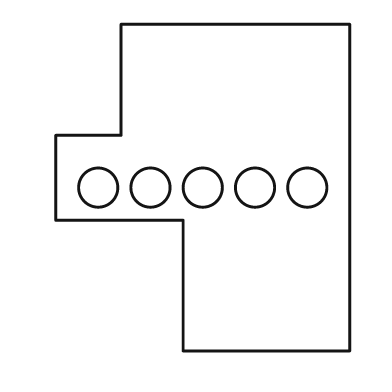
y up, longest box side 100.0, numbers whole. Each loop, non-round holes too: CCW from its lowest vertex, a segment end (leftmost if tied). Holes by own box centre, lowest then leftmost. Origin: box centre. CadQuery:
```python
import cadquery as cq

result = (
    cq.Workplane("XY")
    .moveTo(-6.0, -50.0)
    .lineTo(45.0, -50.0)
    .lineTo(45.0, 50.0)
    .lineTo(-25.0, 50.0)
    .lineTo(-25.0, 16.0)
    .lineTo(-45.0, 16.0)
    .lineTo(-45.0, -10.0)
    .lineTo(-6.0, -10.0)
    .close()
    .moveTo(-32.0, 0.0)
    .circle(6.0)
    .moveTo(-16.0, 0.0)
    .circle(6.0)
    .moveTo(0.0, 0.0)
    .circle(6.0)
    .moveTo(16.0, 0.0)
    .circle(6.0)
    .moveTo(32.0, 0.0)
    .circle(6.0)
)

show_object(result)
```